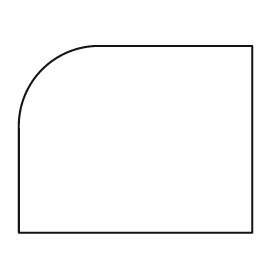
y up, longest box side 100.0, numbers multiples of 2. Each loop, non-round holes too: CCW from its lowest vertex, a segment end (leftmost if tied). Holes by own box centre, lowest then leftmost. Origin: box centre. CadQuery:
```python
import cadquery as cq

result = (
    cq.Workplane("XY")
    .moveTo(-50.0, -40.0)
    .lineTo(50.0, -40.0)
    .lineTo(50.0, 40.0)
    .lineTo(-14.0, 40.0)
    .threePointArc((-40.0, 30.0), (-50.0, 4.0))
    .close()
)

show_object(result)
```